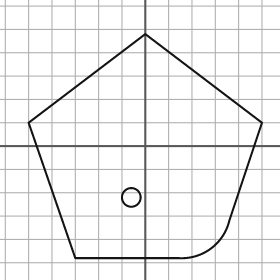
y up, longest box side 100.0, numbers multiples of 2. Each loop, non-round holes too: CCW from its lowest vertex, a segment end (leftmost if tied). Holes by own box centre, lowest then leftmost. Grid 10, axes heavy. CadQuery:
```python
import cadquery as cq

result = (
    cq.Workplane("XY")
    .moveTo(-30.0, -48.0)
    .lineTo(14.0, -48.0)
    .threePointArc((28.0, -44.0), (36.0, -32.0))
    .lineTo(50.0, 10.0)
    .lineTo(0.0, 48.0)
    .lineTo(-50.0, 10.0)
    .close()
    .moveTo(-6.0, -22.0)
    .circle(4.0)
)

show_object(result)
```